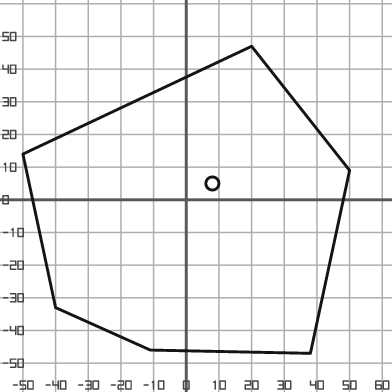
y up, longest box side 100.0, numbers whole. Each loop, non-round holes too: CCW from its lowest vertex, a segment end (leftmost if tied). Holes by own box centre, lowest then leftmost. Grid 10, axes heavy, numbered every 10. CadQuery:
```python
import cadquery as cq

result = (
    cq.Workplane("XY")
    .moveTo(38.0, -47.0)
    .lineTo(50.0, 9.0)
    .lineTo(20.0, 47.0)
    .lineTo(-50.0, 14.0)
    .lineTo(-40.0, -33.0)
    .lineTo(-11.0, -46.0)
    .close()
    .moveTo(8.0, 5.0)
    .circle(2.0)
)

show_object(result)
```